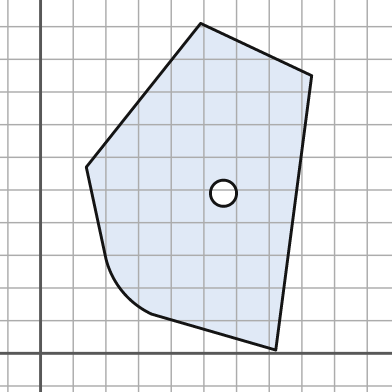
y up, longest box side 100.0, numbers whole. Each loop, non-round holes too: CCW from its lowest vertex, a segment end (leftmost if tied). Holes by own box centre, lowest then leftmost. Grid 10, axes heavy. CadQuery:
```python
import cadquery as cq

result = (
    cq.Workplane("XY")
    .moveTo(72.0, 1.0)
    .lineTo(83.0, 85.0)
    .lineTo(49.0, 101.0)
    .lineTo(14.0, 57.0)
    .lineTo(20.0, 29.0)
    .threePointArc((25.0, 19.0), (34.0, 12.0))
    .close()
    .moveTo(56.0, 49.0)
    .circle(4.0)
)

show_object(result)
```